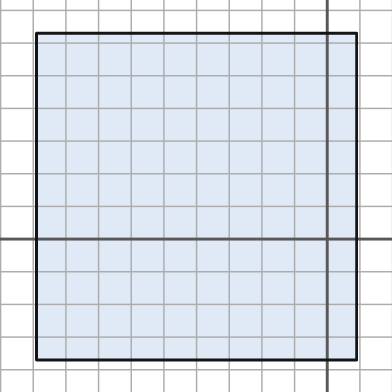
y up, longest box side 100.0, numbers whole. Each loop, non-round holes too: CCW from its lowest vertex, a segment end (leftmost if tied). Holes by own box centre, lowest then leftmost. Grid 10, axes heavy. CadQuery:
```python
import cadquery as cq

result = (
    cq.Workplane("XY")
    .moveTo(-89.0, -37.0)
    .lineTo(9.0, -37.0)
    .lineTo(9.0, 63.0)
    .lineTo(-89.0, 63.0)
    .close()
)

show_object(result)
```